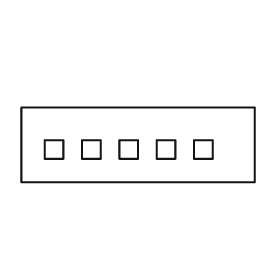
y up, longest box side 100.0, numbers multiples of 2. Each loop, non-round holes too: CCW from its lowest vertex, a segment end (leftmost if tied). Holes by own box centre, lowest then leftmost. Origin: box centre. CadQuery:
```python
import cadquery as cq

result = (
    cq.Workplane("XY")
    .moveTo(-50.0, -16.0)
    .lineTo(50.0, -16.0)
    .lineTo(50.0, 16.0)
    .lineTo(-50.0, 16.0)
    .close()
    .moveTo(-40.0, -6.0)
    .lineTo(-32.0, -6.0)
    .lineTo(-32.0, 2.0)
    .lineTo(-40.0, 2.0)
    .close()
    .moveTo(-24.0, -6.0)
    .lineTo(-16.0, -6.0)
    .lineTo(-16.0, 2.0)
    .lineTo(-24.0, 2.0)
    .close()
    .moveTo(-8.0, -6.0)
    .lineTo(0.0, -6.0)
    .lineTo(0.0, 2.0)
    .lineTo(-8.0, 2.0)
    .close()
    .moveTo(8.0, -6.0)
    .lineTo(16.0, -6.0)
    .lineTo(16.0, 2.0)
    .lineTo(8.0, 2.0)
    .close()
    .moveTo(24.0, -6.0)
    .lineTo(32.0, -6.0)
    .lineTo(32.0, 2.0)
    .lineTo(24.0, 2.0)
    .close()
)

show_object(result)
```